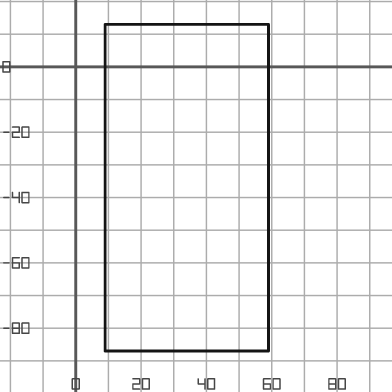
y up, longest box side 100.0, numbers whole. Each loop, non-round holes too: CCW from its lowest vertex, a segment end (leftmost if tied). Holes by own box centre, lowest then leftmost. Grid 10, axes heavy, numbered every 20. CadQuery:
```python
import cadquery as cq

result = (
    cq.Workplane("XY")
    .moveTo(9.0, -87.0)
    .lineTo(59.0, -87.0)
    .lineTo(59.0, 13.0)
    .lineTo(9.0, 13.0)
    .close()
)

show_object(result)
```